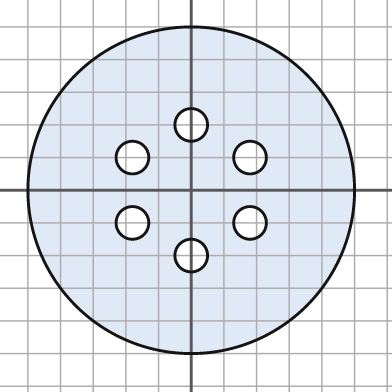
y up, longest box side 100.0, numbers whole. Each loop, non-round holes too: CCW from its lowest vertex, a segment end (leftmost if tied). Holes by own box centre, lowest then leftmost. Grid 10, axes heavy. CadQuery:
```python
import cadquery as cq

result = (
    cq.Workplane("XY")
    .moveTo(0.0, 0.0)
    .circle(50.0)
    .moveTo(0.0, -20.0)
    .circle(5.0)
    .moveTo(-18.0, -10.0)
    .circle(5.0)
    .moveTo(18.0, -10.0)
    .circle(5.0)
    .moveTo(-18.0, 10.0)
    .circle(5.0)
    .moveTo(18.0, 10.0)
    .circle(5.0)
    .moveTo(0.0, 20.0)
    .circle(5.0)
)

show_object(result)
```